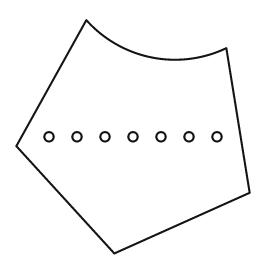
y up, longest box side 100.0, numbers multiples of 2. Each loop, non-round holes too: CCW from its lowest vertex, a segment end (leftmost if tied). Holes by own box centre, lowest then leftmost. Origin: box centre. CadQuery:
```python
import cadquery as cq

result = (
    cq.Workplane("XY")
    .moveTo(-8.0, -50.0)
    .lineTo(50.0, -24.0)
    .lineTo(40.0, 38.0)
    .threePointArc((8.0, 34.0), (-20.0, 50.0))
    .lineTo(-50.0, -4.0)
    .close()
    .moveTo(-36.0, 0.0)
    .circle(2.0)
    .moveTo(-24.0, 0.0)
    .circle(2.0)
    .moveTo(-12.0, 0.0)
    .circle(2.0)
    .moveTo(0.0, 0.0)
    .circle(2.0)
    .moveTo(12.0, 0.0)
    .circle(2.0)
    .moveTo(24.0, 0.0)
    .circle(2.0)
    .moveTo(36.0, 0.0)
    .circle(2.0)
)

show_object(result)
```